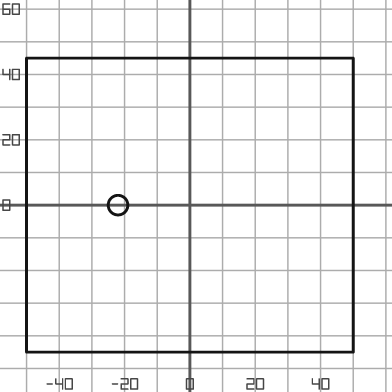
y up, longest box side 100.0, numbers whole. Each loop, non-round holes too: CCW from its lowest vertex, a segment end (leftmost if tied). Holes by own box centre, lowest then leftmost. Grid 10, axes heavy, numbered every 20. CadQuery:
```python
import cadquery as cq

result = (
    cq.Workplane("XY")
    .moveTo(-50.0, -45.0)
    .lineTo(50.0, -45.0)
    .lineTo(50.0, 45.0)
    .lineTo(-50.0, 45.0)
    .close()
    .moveTo(-22.0, 0.0)
    .circle(3.0)
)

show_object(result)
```